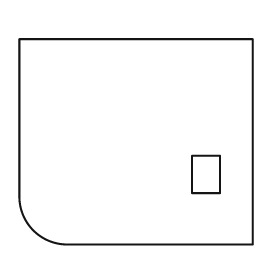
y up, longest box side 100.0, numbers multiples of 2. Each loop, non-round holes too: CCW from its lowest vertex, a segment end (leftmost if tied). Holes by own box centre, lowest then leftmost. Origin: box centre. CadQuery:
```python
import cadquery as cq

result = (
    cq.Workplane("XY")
    .moveTo(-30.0, -44.0)
    .lineTo(50.0, -44.0)
    .lineTo(50.0, 44.0)
    .lineTo(-50.0, 44.0)
    .lineTo(-50.0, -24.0)
    .threePointArc((-44.0, -38.0), (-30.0, -44.0))
    .close()
    .moveTo(24.0, -22.0)
    .lineTo(36.0, -22.0)
    .lineTo(36.0, -6.0)
    .lineTo(24.0, -6.0)
    .close()
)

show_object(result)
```